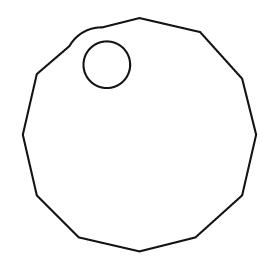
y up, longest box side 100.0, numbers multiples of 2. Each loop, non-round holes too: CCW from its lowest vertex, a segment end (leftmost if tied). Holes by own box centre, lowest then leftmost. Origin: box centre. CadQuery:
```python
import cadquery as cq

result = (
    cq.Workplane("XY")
    .moveTo(0.0, -50.0)
    .lineTo(24.0, -44.0)
    .lineTo(44.0, -26.0)
    .lineTo(50.0, 0.0)
    .lineTo(44.0, 24.0)
    .lineTo(26.0, 44.0)
    .lineTo(0.0, 50.0)
    .lineTo(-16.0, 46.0)
    .threePointArc((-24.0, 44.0), (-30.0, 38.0))
    .lineTo(-44.0, 26.0)
    .lineTo(-50.0, 0.0)
    .lineTo(-44.0, -26.0)
    .lineTo(-26.0, -44.0)
    .close()
    .moveTo(-14.0, 30.0)
    .circle(10.0)
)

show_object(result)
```